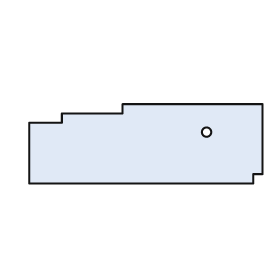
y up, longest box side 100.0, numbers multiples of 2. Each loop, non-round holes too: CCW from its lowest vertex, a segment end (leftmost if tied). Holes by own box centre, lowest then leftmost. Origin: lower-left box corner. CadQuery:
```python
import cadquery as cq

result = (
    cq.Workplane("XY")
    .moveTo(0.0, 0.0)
    .lineTo(96.0, 0.0)
    .lineTo(96.0, 4.0)
    .lineTo(100.0, 4.0)
    .lineTo(100.0, 34.0)
    .lineTo(40.0, 34.0)
    .lineTo(40.0, 30.0)
    .lineTo(14.0, 30.0)
    .lineTo(14.0, 26.0)
    .lineTo(0.0, 26.0)
    .close()
    .moveTo(76.0, 22.0)
    .circle(2.0)
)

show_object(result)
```